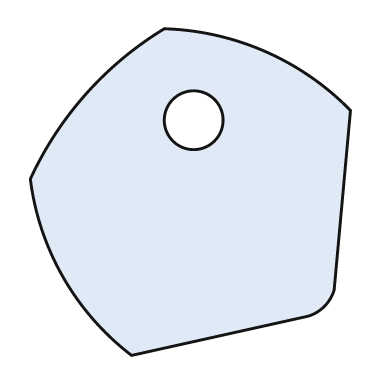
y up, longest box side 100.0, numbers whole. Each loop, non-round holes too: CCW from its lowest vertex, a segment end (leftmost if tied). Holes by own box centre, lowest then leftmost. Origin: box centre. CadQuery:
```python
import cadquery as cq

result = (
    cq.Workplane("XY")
    .moveTo(-18.0, -50.0)
    .lineTo(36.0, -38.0)
    .threePointArc((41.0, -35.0), (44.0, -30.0))
    .lineTo(49.0, 25.0)
    .threePointArc((23.0, 43.0), (-8.0, 50.0))
    .threePointArc((-32.0, 30.0), (-49.0, 4.0))
    .threePointArc((-39.0, -26.0), (-18.0, -50.0))
    .close()
    .moveTo(1.0, 22.0)
    .circle(9.0)
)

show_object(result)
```